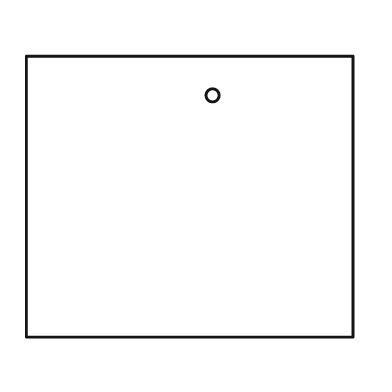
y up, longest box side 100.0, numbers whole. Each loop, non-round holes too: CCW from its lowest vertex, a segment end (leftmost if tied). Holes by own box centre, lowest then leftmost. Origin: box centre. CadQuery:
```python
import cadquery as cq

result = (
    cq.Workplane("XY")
    .moveTo(-50.0, -43.0)
    .lineTo(50.0, -43.0)
    .lineTo(50.0, 43.0)
    .lineTo(-50.0, 43.0)
    .close()
    .moveTo(7.0, 31.0)
    .circle(2.0)
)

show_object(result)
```